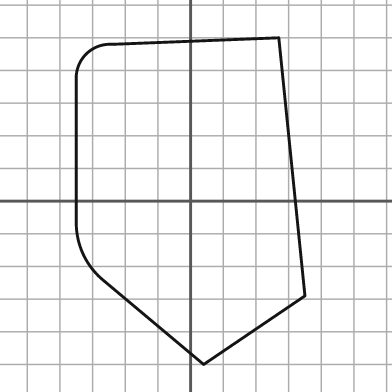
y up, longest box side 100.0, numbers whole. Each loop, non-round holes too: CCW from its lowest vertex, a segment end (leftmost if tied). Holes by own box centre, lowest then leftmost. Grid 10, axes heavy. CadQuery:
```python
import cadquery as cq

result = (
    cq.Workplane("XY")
    .moveTo(4.0, -50.0)
    .lineTo(35.0, -29.0)
    .lineTo(27.0, 50.0)
    .lineTo(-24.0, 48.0)
    .threePointArc((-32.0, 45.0), (-35.0, 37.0))
    .lineTo(-35.0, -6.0)
    .threePointArc((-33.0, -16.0), (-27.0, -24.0))
    .close()
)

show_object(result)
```